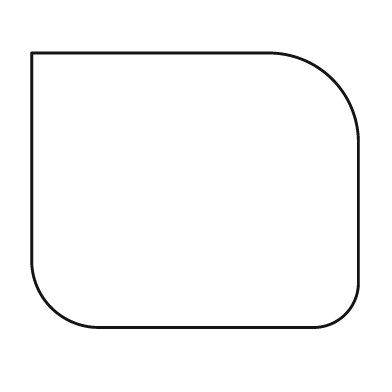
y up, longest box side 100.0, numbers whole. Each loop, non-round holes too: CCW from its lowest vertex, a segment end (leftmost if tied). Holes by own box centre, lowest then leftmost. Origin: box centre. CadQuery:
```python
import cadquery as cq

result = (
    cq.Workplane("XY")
    .moveTo(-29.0, -42.0)
    .lineTo(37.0, -42.0)
    .threePointArc((46.0, -38.0), (50.0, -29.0))
    .lineTo(50.0, 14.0)
    .threePointArc((42.0, 34.0), (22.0, 42.0))
    .lineTo(-50.0, 42.0)
    .lineTo(-50.0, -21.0)
    .threePointArc((-44.0, -36.0), (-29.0, -42.0))
    .close()
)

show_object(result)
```